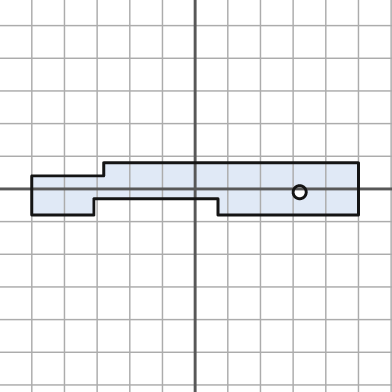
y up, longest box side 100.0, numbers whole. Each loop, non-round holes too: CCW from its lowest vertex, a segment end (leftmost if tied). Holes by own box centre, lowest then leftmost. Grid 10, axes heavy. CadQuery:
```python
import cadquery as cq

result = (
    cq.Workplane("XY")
    .moveTo(-50.0, -8.0)
    .lineTo(-31.0, -8.0)
    .lineTo(-31.0, -3.0)
    .lineTo(7.0, -3.0)
    .lineTo(7.0, -8.0)
    .lineTo(50.0, -8.0)
    .lineTo(50.0, 8.0)
    .lineTo(-28.0, 8.0)
    .lineTo(-28.0, 4.0)
    .lineTo(-50.0, 4.0)
    .close()
    .moveTo(32.0, -1.0)
    .circle(2.0)
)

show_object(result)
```